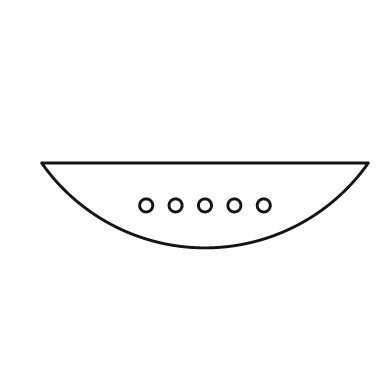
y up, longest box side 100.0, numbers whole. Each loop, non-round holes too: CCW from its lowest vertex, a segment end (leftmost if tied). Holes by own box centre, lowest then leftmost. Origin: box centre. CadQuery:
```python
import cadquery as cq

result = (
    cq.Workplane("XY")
    .moveTo(-50.0, 13.0)
    .threePointArc((0.0, -13.0), (50.0, 13.0))
    .close()
    .moveTo(-18.0, 0.0)
    .circle(2.0)
    .moveTo(-9.0, 0.0)
    .circle(2.0)
    .moveTo(0.0, 0.0)
    .circle(2.0)
    .moveTo(9.0, 0.0)
    .circle(2.0)
    .moveTo(18.0, 0.0)
    .circle(2.0)
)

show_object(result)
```